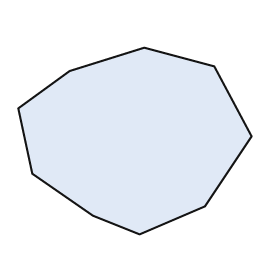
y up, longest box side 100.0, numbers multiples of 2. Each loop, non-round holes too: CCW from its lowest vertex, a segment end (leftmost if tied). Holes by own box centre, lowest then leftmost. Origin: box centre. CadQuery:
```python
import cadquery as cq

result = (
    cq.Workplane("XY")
    .moveTo(2.0, -40.0)
    .lineTo(30.0, -28.0)
    .lineTo(50.0, 2.0)
    .lineTo(34.0, 32.0)
    .lineTo(4.0, 40.0)
    .lineTo(-28.0, 30.0)
    .lineTo(-50.0, 14.0)
    .lineTo(-44.0, -14.0)
    .lineTo(-18.0, -32.0)
    .close()
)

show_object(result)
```